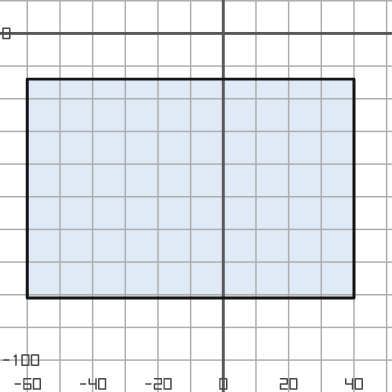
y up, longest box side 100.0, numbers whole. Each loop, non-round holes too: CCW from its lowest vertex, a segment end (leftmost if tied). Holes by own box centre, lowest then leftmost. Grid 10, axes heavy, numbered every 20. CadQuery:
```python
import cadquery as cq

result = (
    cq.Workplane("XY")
    .moveTo(-60.0, -81.0)
    .lineTo(40.0, -81.0)
    .lineTo(40.0, -14.0)
    .lineTo(-60.0, -14.0)
    .close()
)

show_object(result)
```